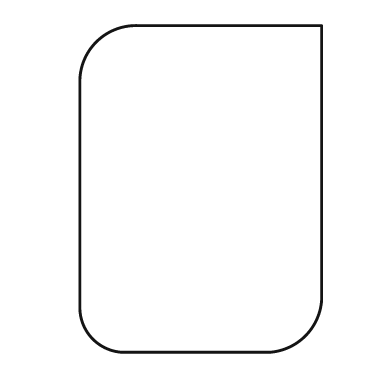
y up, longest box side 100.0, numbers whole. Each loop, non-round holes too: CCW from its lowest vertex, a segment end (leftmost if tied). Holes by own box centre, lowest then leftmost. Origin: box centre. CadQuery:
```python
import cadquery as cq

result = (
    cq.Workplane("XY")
    .moveTo(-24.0, -50.0)
    .lineTo(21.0, -50.0)
    .threePointArc((32.0, -45.0), (37.0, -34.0))
    .lineTo(37.0, 50.0)
    .lineTo(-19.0, 50.0)
    .threePointArc((-32.0, 45.0), (-37.0, 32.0))
    .lineTo(-37.0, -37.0)
    .threePointArc((-33.0, -46.0), (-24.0, -50.0))
    .close()
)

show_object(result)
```